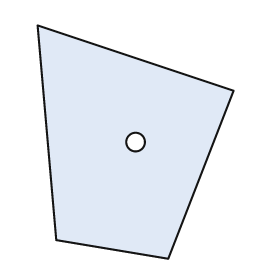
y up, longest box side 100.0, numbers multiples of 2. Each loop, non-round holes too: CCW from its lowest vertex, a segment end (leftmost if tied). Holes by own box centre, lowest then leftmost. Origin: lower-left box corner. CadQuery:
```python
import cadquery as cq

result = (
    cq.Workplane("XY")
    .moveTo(56.0, 0.0)
    .lineTo(84.0, 72.0)
    .lineTo(0.0, 100.0)
    .lineTo(8.0, 8.0)
    .close()
    .moveTo(42.0, 50.0)
    .circle(4.0)
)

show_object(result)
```